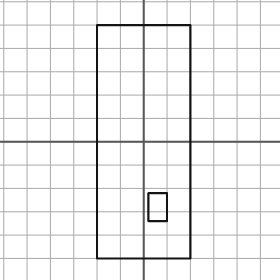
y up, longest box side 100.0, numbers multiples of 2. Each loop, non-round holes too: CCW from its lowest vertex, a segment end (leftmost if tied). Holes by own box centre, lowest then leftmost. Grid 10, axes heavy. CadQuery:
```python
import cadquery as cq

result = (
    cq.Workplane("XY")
    .moveTo(-20.0, -50.0)
    .lineTo(20.0, -50.0)
    .lineTo(20.0, 50.0)
    .lineTo(-20.0, 50.0)
    .close()
    .moveTo(2.0, -34.0)
    .lineTo(10.0, -34.0)
    .lineTo(10.0, -22.0)
    .lineTo(2.0, -22.0)
    .close()
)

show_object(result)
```